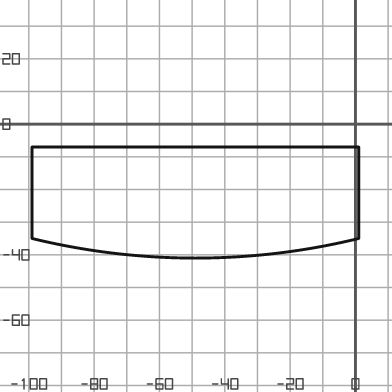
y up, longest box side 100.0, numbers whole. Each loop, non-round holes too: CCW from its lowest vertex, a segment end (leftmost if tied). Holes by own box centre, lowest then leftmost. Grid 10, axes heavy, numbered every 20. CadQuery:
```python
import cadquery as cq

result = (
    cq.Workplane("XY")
    .moveTo(-99.0, -35.0)
    .threePointArc((-49.0, -41.0), (1.0, -35.0))
    .lineTo(1.0, -7.0)
    .lineTo(-99.0, -7.0)
    .close()
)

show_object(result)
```